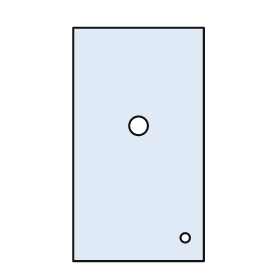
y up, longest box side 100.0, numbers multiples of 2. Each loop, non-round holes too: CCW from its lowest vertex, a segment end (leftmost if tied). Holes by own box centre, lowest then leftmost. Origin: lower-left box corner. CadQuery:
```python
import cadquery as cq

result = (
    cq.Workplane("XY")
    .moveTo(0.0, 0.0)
    .lineTo(56.0, 0.0)
    .lineTo(56.0, 100.0)
    .lineTo(0.0, 100.0)
    .close()
    .moveTo(48.0, 10.0)
    .circle(2.0)
    .moveTo(28.0, 58.0)
    .circle(4.0)
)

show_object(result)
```